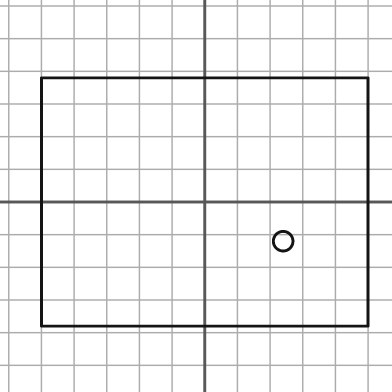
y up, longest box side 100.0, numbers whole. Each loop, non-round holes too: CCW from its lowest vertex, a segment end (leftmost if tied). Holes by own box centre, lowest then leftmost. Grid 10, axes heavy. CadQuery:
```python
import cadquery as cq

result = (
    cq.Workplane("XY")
    .moveTo(-50.0, -38.0)
    .lineTo(50.0, -38.0)
    .lineTo(50.0, 38.0)
    .lineTo(-50.0, 38.0)
    .close()
    .moveTo(24.0, -12.0)
    .circle(3.0)
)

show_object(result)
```